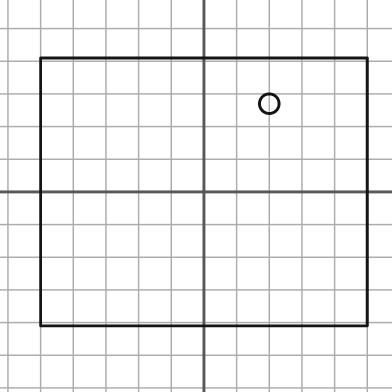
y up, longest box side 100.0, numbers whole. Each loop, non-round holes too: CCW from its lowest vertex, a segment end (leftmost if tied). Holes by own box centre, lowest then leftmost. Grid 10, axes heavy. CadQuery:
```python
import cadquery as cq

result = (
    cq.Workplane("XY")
    .moveTo(-50.0, -41.0)
    .lineTo(50.0, -41.0)
    .lineTo(50.0, 41.0)
    .lineTo(-50.0, 41.0)
    .close()
    .moveTo(20.0, 27.0)
    .circle(3.0)
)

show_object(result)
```